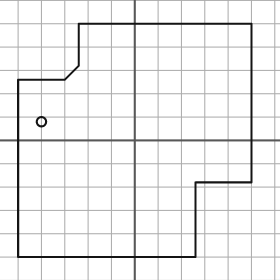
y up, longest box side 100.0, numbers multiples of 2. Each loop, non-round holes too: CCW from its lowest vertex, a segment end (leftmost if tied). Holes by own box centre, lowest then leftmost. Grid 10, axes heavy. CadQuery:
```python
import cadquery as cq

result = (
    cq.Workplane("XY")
    .moveTo(-50.0, -50.0)
    .lineTo(26.0, -50.0)
    .lineTo(26.0, -18.0)
    .lineTo(50.0, -18.0)
    .lineTo(50.0, 50.0)
    .lineTo(-24.0, 50.0)
    .lineTo(-24.0, 32.0)
    .lineTo(-30.0, 26.0)
    .lineTo(-50.0, 26.0)
    .close()
    .moveTo(-40.0, 8.0)
    .circle(2.0)
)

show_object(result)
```